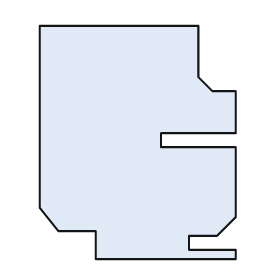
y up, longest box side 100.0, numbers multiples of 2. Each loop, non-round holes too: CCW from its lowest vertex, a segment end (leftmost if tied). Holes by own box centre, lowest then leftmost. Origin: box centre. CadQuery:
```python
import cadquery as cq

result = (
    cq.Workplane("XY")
    .moveTo(-18.0, -50.0)
    .lineTo(42.0, -50.0)
    .lineTo(42.0, -46.0)
    .lineTo(22.0, -46.0)
    .lineTo(22.0, -40.0)
    .lineTo(34.0, -40.0)
    .lineTo(42.0, -32.0)
    .lineTo(42.0, -2.0)
    .lineTo(10.0, -2.0)
    .lineTo(10.0, 4.0)
    .lineTo(42.0, 4.0)
    .lineTo(42.0, 22.0)
    .lineTo(32.0, 22.0)
    .lineTo(26.0, 28.0)
    .lineTo(26.0, 50.0)
    .lineTo(-42.0, 50.0)
    .lineTo(-42.0, -28.0)
    .lineTo(-34.0, -38.0)
    .lineTo(-18.0, -38.0)
    .close()
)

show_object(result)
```